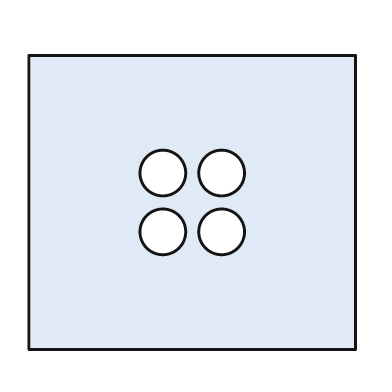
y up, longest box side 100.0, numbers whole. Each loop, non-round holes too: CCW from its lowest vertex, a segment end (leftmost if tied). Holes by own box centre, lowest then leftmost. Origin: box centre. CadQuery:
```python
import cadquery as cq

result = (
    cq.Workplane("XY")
    .moveTo(-50.0, -45.0)
    .lineTo(50.0, -45.0)
    .lineTo(50.0, 45.0)
    .lineTo(-50.0, 45.0)
    .close()
    .moveTo(-9.0, -9.0)
    .circle(7.0)
    .moveTo(9.0, -9.0)
    .circle(7.0)
    .moveTo(-9.0, 9.0)
    .circle(7.0)
    .moveTo(9.0, 9.0)
    .circle(7.0)
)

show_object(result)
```